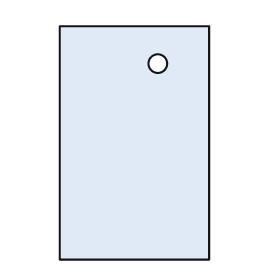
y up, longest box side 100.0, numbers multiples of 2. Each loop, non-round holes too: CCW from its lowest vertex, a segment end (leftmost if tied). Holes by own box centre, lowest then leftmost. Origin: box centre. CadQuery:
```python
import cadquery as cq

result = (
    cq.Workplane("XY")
    .moveTo(-32.0, -50.0)
    .lineTo(32.0, -50.0)
    .lineTo(32.0, 50.0)
    .lineTo(-32.0, 50.0)
    .close()
    .moveTo(10.0, 34.0)
    .circle(4.0)
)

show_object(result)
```